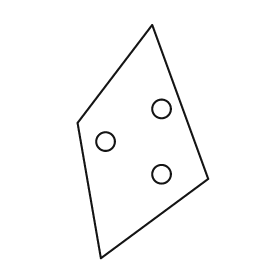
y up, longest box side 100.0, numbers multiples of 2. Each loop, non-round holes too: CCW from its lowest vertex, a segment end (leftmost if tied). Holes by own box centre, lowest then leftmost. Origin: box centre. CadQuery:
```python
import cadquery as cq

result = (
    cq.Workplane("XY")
    .moveTo(-18.0, -50.0)
    .lineTo(28.0, -16.0)
    .lineTo(4.0, 50.0)
    .lineTo(-28.0, 8.0)
    .close()
    .moveTo(8.0, -14.0)
    .circle(4.0)
    .moveTo(-16.0, 0.0)
    .circle(4.0)
    .moveTo(8.0, 14.0)
    .circle(4.0)
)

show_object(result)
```